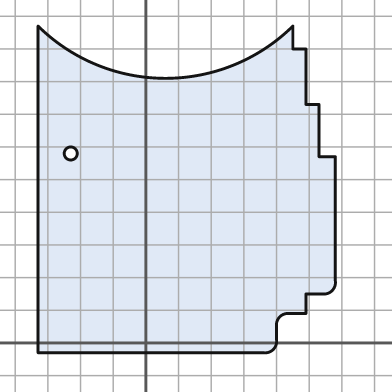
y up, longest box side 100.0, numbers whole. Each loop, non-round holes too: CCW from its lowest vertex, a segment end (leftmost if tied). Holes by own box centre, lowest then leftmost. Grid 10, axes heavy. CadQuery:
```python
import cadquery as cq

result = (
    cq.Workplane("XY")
    .moveTo(-33.0, -3.0)
    .lineTo(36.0, -3.0)
    .threePointArc((39.0, -2.0), (40.0, 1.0))
    .lineTo(40.0, 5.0)
    .threePointArc((41.0, 8.0), (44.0, 9.0))
    .lineTo(49.0, 9.0)
    .lineTo(49.0, 15.0)
    .lineTo(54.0, 15.0)
    .threePointArc((57.0, 16.0), (58.0, 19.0))
    .lineTo(58.0, 57.0)
    .lineTo(53.0, 57.0)
    .lineTo(53.0, 73.0)
    .lineTo(49.0, 73.0)
    .lineTo(49.0, 90.0)
    .lineTo(45.0, 90.0)
    .lineTo(45.0, 97.0)
    .threePointArc((6.0, 81.0), (-33.0, 97.0))
    .close()
    .moveTo(-23.0, 58.0)
    .circle(2.0)
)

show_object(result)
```